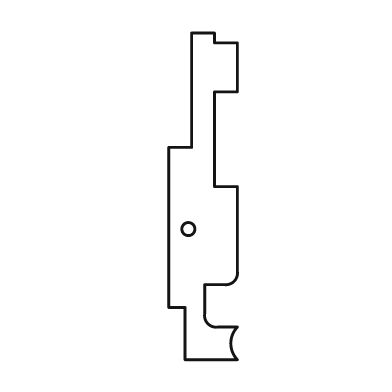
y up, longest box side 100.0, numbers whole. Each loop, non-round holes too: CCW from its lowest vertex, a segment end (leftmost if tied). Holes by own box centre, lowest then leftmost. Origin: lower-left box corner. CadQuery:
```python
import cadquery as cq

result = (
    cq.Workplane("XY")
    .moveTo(5.0, 0.0)
    .lineTo(21.0, 0.0)
    .threePointArc((19.0, 5.0), (21.0, 10.0))
    .lineTo(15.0, 10.0)
    .threePointArc((12.0, 11.0), (11.0, 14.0))
    .lineTo(11.0, 23.0)
    .lineTo(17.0, 23.0)
    .threePointArc((20.0, 24.0), (21.0, 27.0))
    .lineTo(21.0, 53.0)
    .lineTo(14.0, 53.0)
    .lineTo(14.0, 82.0)
    .lineTo(21.0, 82.0)
    .lineTo(21.0, 97.0)
    .lineTo(14.0, 97.0)
    .lineTo(14.0, 100.0)
    .lineTo(7.0, 100.0)
    .lineTo(7.0, 65.0)
    .lineTo(0.0, 65.0)
    .lineTo(0.0, 16.0)
    .lineTo(5.0, 16.0)
    .close()
    .moveTo(6.0, 40.0)
    .circle(2.0)
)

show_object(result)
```